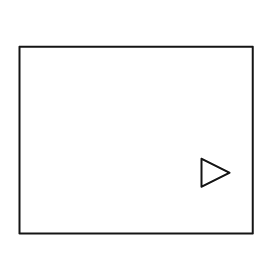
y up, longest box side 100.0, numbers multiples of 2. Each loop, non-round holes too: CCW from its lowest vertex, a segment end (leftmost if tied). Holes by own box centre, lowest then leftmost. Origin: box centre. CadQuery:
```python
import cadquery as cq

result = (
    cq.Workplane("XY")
    .moveTo(-50.0, -40.0)
    .lineTo(50.0, -40.0)
    .lineTo(50.0, 40.0)
    .lineTo(-50.0, 40.0)
    .close()
    .moveTo(28.0, -20.0)
    .lineTo(40.0, -14.0)
    .lineTo(28.0, -8.0)
    .close()
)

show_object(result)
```